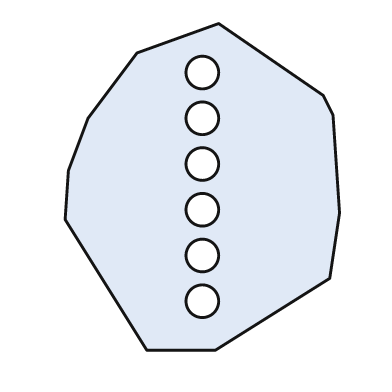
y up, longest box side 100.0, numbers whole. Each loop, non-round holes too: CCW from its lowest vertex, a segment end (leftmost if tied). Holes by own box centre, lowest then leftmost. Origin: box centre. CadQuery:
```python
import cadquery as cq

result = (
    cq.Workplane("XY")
    .moveTo(-17.0, -50.0)
    .lineTo(4.0, -50.0)
    .lineTo(39.0, -28.0)
    .lineTo(42.0, -8.0)
    .lineTo(40.0, 22.0)
    .lineTo(37.0, 28.0)
    .lineTo(5.0, 50.0)
    .lineTo(-20.0, 41.0)
    .lineTo(-35.0, 21.0)
    .lineTo(-41.0, 5.0)
    .lineTo(-42.0, -10.0)
    .close()
    .moveTo(0.0, -35.0)
    .circle(5.0)
    .moveTo(0.0, -21.0)
    .circle(5.0)
    .moveTo(0.0, -7.0)
    .circle(5.0)
    .moveTo(0.0, 7.0)
    .circle(5.0)
    .moveTo(0.0, 21.0)
    .circle(5.0)
    .moveTo(0.0, 35.0)
    .circle(5.0)
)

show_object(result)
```